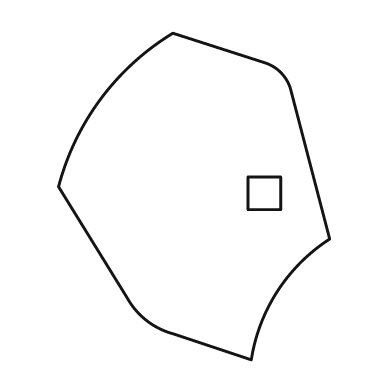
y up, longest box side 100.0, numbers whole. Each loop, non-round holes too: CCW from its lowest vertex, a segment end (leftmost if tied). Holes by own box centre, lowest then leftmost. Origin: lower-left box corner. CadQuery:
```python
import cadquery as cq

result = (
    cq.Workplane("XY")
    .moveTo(59.0, 0.0)
    .threePointArc((67.0, 21.0), (83.0, 37.0))
    .lineTo(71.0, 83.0)
    .threePointArc((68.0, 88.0), (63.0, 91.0))
    .lineTo(35.0, 100.0)
    .threePointArc((13.0, 80.0), (0.0, 53.0))
    .lineTo(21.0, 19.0)
    .threePointArc((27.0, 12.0), (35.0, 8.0))
    .close()
    .moveTo(58.0, 46.0)
    .lineTo(68.0, 46.0)
    .lineTo(68.0, 56.0)
    .lineTo(58.0, 56.0)
    .close()
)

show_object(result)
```